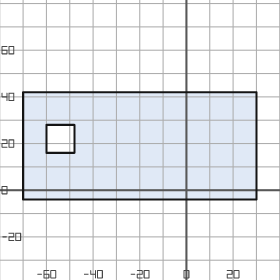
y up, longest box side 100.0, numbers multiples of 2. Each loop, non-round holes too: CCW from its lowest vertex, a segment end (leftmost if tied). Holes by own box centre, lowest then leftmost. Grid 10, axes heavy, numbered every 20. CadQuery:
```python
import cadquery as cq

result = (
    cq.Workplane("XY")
    .moveTo(-70.0, -4.0)
    .lineTo(30.0, -4.0)
    .lineTo(30.0, 42.0)
    .lineTo(-70.0, 42.0)
    .close()
    .moveTo(-60.0, 16.0)
    .lineTo(-48.0, 16.0)
    .lineTo(-48.0, 28.0)
    .lineTo(-60.0, 28.0)
    .close()
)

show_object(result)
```